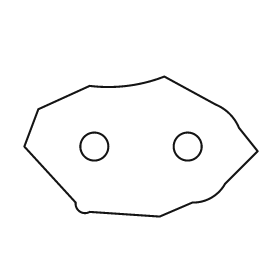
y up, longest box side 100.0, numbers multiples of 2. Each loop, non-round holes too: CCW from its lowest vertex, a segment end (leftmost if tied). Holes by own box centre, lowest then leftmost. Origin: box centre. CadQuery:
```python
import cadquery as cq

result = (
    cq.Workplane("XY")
    .moveTo(8.0, -30.0)
    .lineTo(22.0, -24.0)
    .threePointArc((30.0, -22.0), (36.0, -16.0))
    .lineTo(50.0, -2.0)
    .lineTo(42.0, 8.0)
    .threePointArc((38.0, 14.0), (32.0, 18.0))
    .lineTo(10.0, 30.0)
    .threePointArc((-6.0, 26.0), (-22.0, 26.0))
    .lineTo(-44.0, 16.0)
    .lineTo(-50.0, 0.0)
    .lineTo(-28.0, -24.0)
    .threePointArc((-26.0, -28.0), (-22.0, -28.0))
    .close()
    .moveTo(-20.0, 0.0)
    .circle(6.0)
    .moveTo(20.0, 0.0)
    .circle(6.0)
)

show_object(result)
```